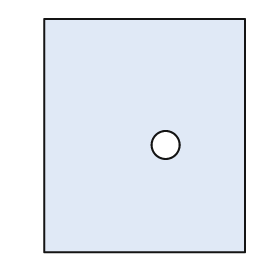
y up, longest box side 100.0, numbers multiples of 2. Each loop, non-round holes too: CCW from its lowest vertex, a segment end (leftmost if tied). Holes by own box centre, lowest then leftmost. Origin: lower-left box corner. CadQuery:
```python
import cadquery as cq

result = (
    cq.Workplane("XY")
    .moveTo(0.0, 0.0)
    .lineTo(86.0, 0.0)
    .lineTo(86.0, 100.0)
    .lineTo(0.0, 100.0)
    .close()
    .moveTo(52.0, 46.0)
    .circle(6.0)
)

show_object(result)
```